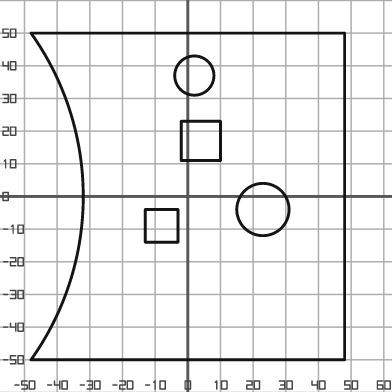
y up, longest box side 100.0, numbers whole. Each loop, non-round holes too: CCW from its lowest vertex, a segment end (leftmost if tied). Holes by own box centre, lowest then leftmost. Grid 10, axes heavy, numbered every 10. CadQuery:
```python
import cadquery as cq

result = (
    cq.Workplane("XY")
    .moveTo(-48.0, -50.0)
    .lineTo(48.0, -50.0)
    .lineTo(48.0, 50.0)
    .lineTo(-48.0, 50.0)
    .threePointArc((-32.0, 0.0), (-48.0, -50.0))
    .close()
    .moveTo(-13.0, -14.0)
    .lineTo(-3.0, -14.0)
    .lineTo(-3.0, -4.0)
    .lineTo(-13.0, -4.0)
    .close()
    .moveTo(23.0, -4.0)
    .circle(8.0)
    .moveTo(-2.0, 11.0)
    .lineTo(10.0, 11.0)
    .lineTo(10.0, 23.0)
    .lineTo(-2.0, 23.0)
    .close()
    .moveTo(2.0, 37.0)
    .circle(6.0)
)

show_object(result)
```